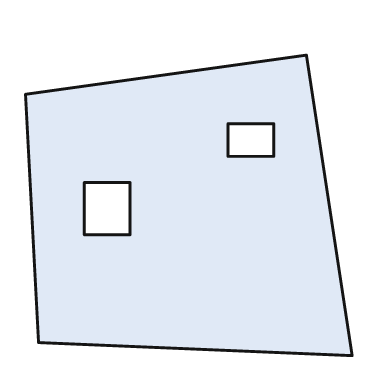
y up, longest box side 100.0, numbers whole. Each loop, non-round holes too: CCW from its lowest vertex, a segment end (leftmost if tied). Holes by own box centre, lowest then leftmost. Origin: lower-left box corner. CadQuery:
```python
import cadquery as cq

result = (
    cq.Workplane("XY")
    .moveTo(100.0, 0.0)
    .lineTo(86.0, 92.0)
    .lineTo(0.0, 80.0)
    .lineTo(4.0, 4.0)
    .close()
    .moveTo(18.0, 37.0)
    .lineTo(32.0, 37.0)
    .lineTo(32.0, 53.0)
    .lineTo(18.0, 53.0)
    .close()
    .moveTo(62.0, 61.0)
    .lineTo(76.0, 61.0)
    .lineTo(76.0, 71.0)
    .lineTo(62.0, 71.0)
    .close()
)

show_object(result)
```